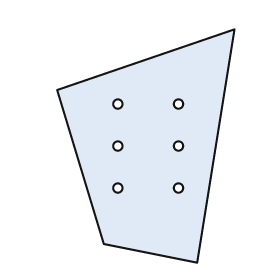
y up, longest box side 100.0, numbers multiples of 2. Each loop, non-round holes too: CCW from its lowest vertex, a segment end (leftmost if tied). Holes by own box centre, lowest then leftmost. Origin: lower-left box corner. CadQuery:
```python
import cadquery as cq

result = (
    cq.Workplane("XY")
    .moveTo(60.0, 0.0)
    .lineTo(76.0, 100.0)
    .lineTo(0.0, 74.0)
    .lineTo(20.0, 8.0)
    .close()
    .moveTo(26.0, 32.0)
    .circle(2.0)
    .moveTo(52.0, 32.0)
    .circle(2.0)
    .moveTo(26.0, 50.0)
    .circle(2.0)
    .moveTo(52.0, 50.0)
    .circle(2.0)
    .moveTo(26.0, 68.0)
    .circle(2.0)
    .moveTo(52.0, 68.0)
    .circle(2.0)
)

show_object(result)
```